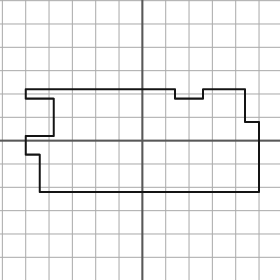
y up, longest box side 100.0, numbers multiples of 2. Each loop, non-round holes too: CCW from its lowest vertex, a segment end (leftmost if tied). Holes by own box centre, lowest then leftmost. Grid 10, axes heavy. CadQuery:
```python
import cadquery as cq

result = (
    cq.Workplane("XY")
    .moveTo(-44.0, -22.0)
    .lineTo(50.0, -22.0)
    .lineTo(50.0, 8.0)
    .lineTo(44.0, 8.0)
    .lineTo(44.0, 22.0)
    .lineTo(26.0, 22.0)
    .lineTo(26.0, 18.0)
    .lineTo(14.0, 18.0)
    .lineTo(14.0, 22.0)
    .lineTo(-50.0, 22.0)
    .lineTo(-50.0, 18.0)
    .lineTo(-38.0, 18.0)
    .lineTo(-38.0, 2.0)
    .lineTo(-50.0, 2.0)
    .lineTo(-50.0, -6.0)
    .lineTo(-44.0, -6.0)
    .close()
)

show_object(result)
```